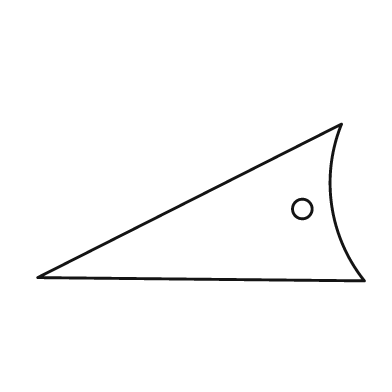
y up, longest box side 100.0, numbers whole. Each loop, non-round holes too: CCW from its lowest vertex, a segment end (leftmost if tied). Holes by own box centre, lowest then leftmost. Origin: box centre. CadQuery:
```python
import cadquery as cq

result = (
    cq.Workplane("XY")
    .moveTo(50.0, -24.0)
    .threePointArc((40.0, -1.0), (43.0, 24.0))
    .lineTo(-50.0, -23.0)
    .close()
    .moveTo(31.0, -2.0)
    .circle(3.0)
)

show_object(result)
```